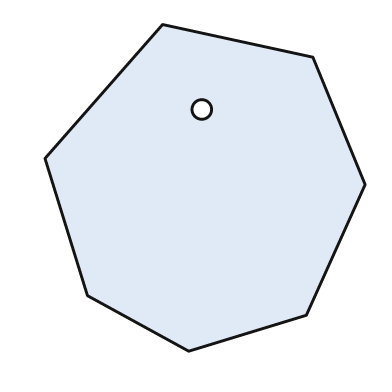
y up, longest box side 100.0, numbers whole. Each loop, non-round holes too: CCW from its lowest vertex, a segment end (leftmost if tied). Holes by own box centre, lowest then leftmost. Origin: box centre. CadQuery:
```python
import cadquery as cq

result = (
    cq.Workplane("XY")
    .moveTo(-5.0, -50.0)
    .lineTo(31.0, -39.0)
    .lineTo(49.0, 1.0)
    .lineTo(33.0, 40.0)
    .lineTo(-13.0, 50.0)
    .lineTo(-49.0, 9.0)
    .lineTo(-36.0, -33.0)
    .close()
    .moveTo(-1.0, 24.0)
    .circle(3.0)
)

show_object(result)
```